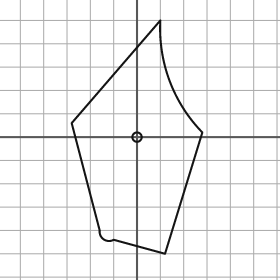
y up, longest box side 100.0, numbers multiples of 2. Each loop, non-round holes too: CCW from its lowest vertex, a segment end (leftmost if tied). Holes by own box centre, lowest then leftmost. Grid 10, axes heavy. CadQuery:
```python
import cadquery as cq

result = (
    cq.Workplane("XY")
    .moveTo(12.0, -50.0)
    .lineTo(28.0, 2.0)
    .threePointArc((14.0, 24.0), (10.0, 50.0))
    .lineTo(-28.0, 6.0)
    .lineTo(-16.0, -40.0)
    .threePointArc((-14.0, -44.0), (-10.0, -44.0))
    .close()
    .moveTo(0.0, 0.0)
    .circle(2.0)
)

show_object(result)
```